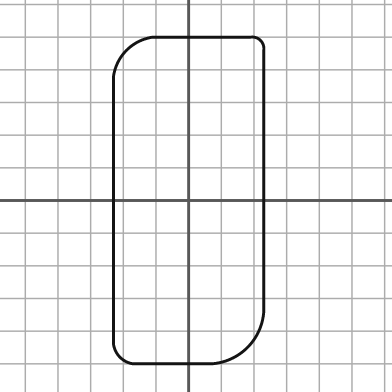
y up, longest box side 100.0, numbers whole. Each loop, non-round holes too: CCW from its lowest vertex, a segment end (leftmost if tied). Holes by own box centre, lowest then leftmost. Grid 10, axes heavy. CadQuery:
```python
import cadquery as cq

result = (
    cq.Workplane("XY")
    .moveTo(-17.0, -50.0)
    .lineTo(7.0, -50.0)
    .threePointArc((18.0, -45.0), (23.0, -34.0))
    .lineTo(23.0, 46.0)
    .threePointArc((22.0, 49.0), (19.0, 50.0))
    .lineTo(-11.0, 50.0)
    .threePointArc((-19.0, 46.0), (-23.0, 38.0))
    .lineTo(-23.0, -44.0)
    .threePointArc((-21.0, -48.0), (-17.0, -50.0))
    .close()
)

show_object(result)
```